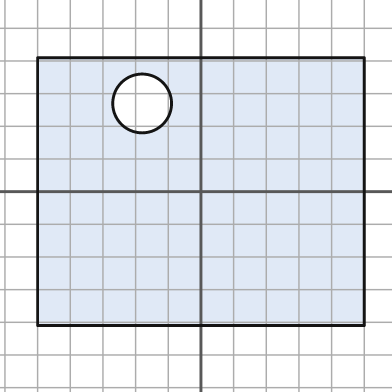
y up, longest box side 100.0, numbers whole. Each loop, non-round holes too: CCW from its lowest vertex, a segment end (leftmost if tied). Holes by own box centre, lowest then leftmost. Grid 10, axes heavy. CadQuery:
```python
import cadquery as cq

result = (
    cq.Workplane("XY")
    .moveTo(-50.0, -41.0)
    .lineTo(50.0, -41.0)
    .lineTo(50.0, 41.0)
    .lineTo(-50.0, 41.0)
    .close()
    .moveTo(-18.0, 27.0)
    .circle(9.0)
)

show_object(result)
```